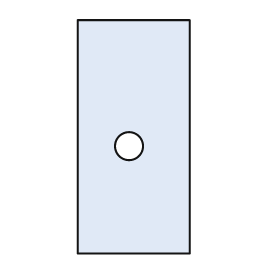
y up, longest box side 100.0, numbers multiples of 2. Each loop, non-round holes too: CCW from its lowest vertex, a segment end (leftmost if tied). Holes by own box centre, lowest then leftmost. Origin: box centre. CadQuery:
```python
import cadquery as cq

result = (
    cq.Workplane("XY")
    .moveTo(-24.0, -50.0)
    .lineTo(24.0, -50.0)
    .lineTo(24.0, 50.0)
    .lineTo(-24.0, 50.0)
    .close()
    .moveTo(-2.0, -4.0)
    .circle(6.0)
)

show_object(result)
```